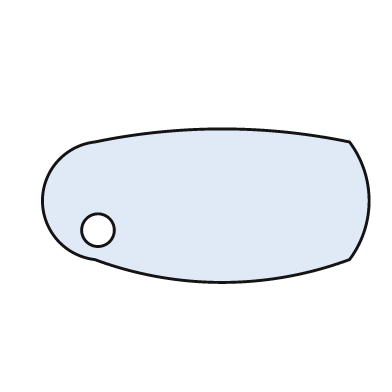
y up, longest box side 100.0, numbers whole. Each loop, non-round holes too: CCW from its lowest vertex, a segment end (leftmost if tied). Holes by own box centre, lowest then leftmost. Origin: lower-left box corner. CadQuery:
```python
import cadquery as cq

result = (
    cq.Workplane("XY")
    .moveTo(16.0, 7.0)
    .threePointArc((55.0, 0.0), (94.0, 7.0))
    .threePointArc((100.0, 25.0), (94.0, 43.0))
    .threePointArc((55.0, 47.0), (16.0, 43.0))
    .threePointArc((0.0, 25.0), (16.0, 7.0))
    .close()
    .moveTo(17.0, 16.0)
    .circle(5.0)
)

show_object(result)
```